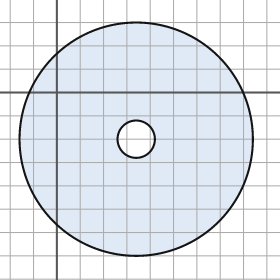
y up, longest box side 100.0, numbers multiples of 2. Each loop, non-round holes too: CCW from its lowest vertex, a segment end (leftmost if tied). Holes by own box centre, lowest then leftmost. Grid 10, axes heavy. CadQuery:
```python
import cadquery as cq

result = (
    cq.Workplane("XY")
    .moveTo(34.0, -20.0)
    .circle(50.0)
    .moveTo(34.0, -20.0)
    .circle(8.0)
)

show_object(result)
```